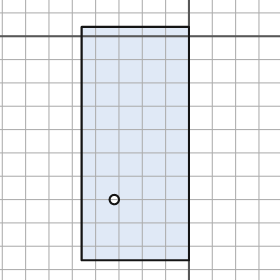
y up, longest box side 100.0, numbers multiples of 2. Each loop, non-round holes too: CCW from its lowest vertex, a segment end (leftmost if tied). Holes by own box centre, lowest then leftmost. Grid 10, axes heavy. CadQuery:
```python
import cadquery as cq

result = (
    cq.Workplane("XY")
    .moveTo(-46.0, -96.0)
    .lineTo(0.0, -96.0)
    .lineTo(0.0, 4.0)
    .lineTo(-46.0, 4.0)
    .close()
    .moveTo(-32.0, -70.0)
    .circle(2.0)
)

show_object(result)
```